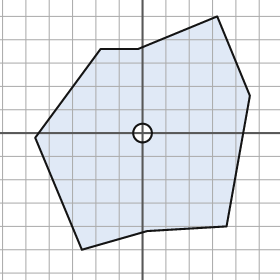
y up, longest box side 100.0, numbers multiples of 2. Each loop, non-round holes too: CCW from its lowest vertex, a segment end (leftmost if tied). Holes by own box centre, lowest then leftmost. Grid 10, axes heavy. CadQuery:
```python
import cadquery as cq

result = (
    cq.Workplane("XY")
    .moveTo(-26.0, -50.0)
    .lineTo(2.0, -42.0)
    .lineTo(36.0, -40.0)
    .lineTo(46.0, 16.0)
    .lineTo(32.0, 50.0)
    .lineTo(-2.0, 36.0)
    .lineTo(-18.0, 36.0)
    .lineTo(-46.0, -2.0)
    .close()
    .moveTo(0.0, 0.0)
    .circle(4.0)
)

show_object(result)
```